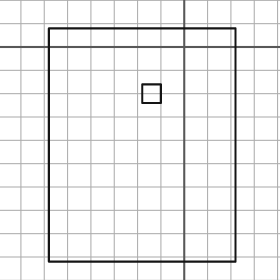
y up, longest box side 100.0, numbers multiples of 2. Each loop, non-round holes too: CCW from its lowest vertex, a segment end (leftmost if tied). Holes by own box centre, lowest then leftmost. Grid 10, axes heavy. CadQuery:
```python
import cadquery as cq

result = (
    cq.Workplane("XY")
    .moveTo(-58.0, -92.0)
    .lineTo(22.0, -92.0)
    .lineTo(22.0, 8.0)
    .lineTo(-58.0, 8.0)
    .close()
    .moveTo(-18.0, -24.0)
    .lineTo(-10.0, -24.0)
    .lineTo(-10.0, -16.0)
    .lineTo(-18.0, -16.0)
    .close()
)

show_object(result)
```